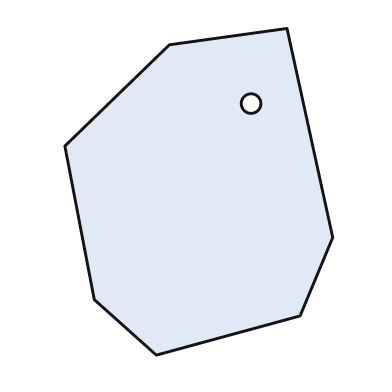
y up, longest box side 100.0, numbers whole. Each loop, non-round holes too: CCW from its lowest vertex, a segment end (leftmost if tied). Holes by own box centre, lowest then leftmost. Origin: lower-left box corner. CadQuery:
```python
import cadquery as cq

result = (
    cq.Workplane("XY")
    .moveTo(28.0, 0.0)
    .lineTo(72.0, 12.0)
    .lineTo(82.0, 36.0)
    .lineTo(68.0, 100.0)
    .lineTo(32.0, 95.0)
    .lineTo(0.0, 64.0)
    .lineTo(9.0, 17.0)
    .close()
    .moveTo(57.0, 77.0)
    .circle(3.0)
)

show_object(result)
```